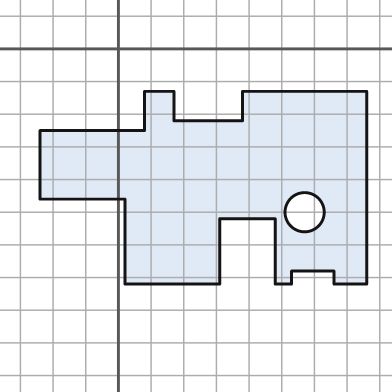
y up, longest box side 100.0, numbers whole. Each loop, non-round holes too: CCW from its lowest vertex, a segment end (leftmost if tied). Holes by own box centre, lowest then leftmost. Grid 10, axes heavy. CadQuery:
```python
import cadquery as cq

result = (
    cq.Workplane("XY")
    .moveTo(2.0, -72.0)
    .lineTo(31.0, -72.0)
    .lineTo(31.0, -52.0)
    .lineTo(48.0, -52.0)
    .lineTo(48.0, -72.0)
    .lineTo(53.0, -72.0)
    .lineTo(53.0, -68.0)
    .lineTo(66.0, -68.0)
    .lineTo(66.0, -72.0)
    .lineTo(76.0, -72.0)
    .lineTo(76.0, -13.0)
    .lineTo(38.0, -13.0)
    .lineTo(38.0, -22.0)
    .lineTo(17.0, -22.0)
    .lineTo(17.0, -13.0)
    .lineTo(8.0, -13.0)
    .lineTo(8.0, -25.0)
    .lineTo(-24.0, -25.0)
    .lineTo(-24.0, -46.0)
    .lineTo(2.0, -46.0)
    .close()
    .moveTo(57.0, -50.0)
    .circle(6.0)
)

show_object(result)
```